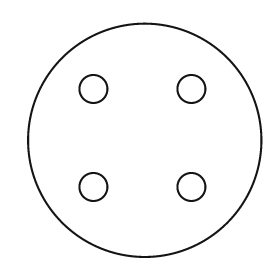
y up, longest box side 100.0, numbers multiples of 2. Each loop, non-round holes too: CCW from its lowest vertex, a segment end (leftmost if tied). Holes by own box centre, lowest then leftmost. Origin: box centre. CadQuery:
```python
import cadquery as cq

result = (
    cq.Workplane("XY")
    .moveTo(0.0, 0.0)
    .circle(50.0)
    .moveTo(-22.0, -20.0)
    .circle(6.0)
    .moveTo(20.0, -20.0)
    .circle(6.0)
    .moveTo(-22.0, 22.0)
    .circle(6.0)
    .moveTo(20.0, 22.0)
    .circle(6.0)
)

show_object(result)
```